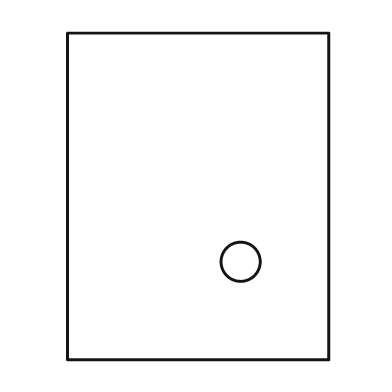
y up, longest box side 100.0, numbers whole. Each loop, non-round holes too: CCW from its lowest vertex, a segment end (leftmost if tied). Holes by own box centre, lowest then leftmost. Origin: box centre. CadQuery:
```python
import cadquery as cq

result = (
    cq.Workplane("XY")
    .moveTo(-40.0, -50.0)
    .lineTo(40.0, -50.0)
    .lineTo(40.0, 50.0)
    .lineTo(-40.0, 50.0)
    .close()
    .moveTo(13.0, -20.0)
    .circle(6.0)
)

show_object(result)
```